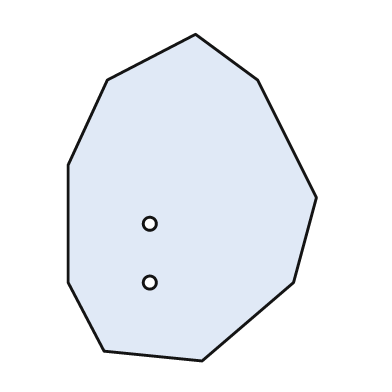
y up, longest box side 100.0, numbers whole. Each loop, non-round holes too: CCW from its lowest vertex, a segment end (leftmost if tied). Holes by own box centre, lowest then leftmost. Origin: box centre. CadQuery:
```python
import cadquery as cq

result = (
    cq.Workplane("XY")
    .moveTo(3.0, -50.0)
    .lineTo(31.0, -26.0)
    .lineTo(38.0, 0.0)
    .lineTo(20.0, 36.0)
    .lineTo(1.0, 50.0)
    .lineTo(-26.0, 36.0)
    .lineTo(-38.0, 10.0)
    .lineTo(-38.0, -26.0)
    .lineTo(-27.0, -47.0)
    .close()
    .moveTo(-13.0, -26.0)
    .circle(2.0)
    .moveTo(-13.0, -8.0)
    .circle(2.0)
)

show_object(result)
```